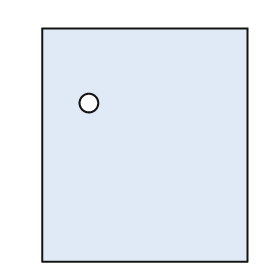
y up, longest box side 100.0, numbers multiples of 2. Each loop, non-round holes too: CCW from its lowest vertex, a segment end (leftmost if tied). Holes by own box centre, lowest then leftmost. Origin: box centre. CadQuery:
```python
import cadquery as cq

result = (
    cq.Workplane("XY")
    .moveTo(-44.0, -50.0)
    .lineTo(44.0, -50.0)
    .lineTo(44.0, 50.0)
    .lineTo(-44.0, 50.0)
    .close()
    .moveTo(-24.0, 18.0)
    .circle(4.0)
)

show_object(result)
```